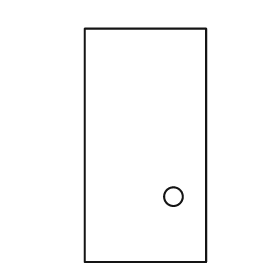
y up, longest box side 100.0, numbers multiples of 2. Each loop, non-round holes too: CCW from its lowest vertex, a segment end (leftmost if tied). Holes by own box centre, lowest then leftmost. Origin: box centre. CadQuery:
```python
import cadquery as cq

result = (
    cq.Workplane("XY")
    .moveTo(-26.0, -50.0)
    .lineTo(26.0, -50.0)
    .lineTo(26.0, 50.0)
    .lineTo(-26.0, 50.0)
    .close()
    .moveTo(12.0, -22.0)
    .circle(4.0)
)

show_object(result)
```